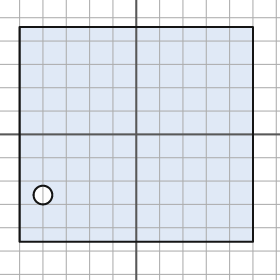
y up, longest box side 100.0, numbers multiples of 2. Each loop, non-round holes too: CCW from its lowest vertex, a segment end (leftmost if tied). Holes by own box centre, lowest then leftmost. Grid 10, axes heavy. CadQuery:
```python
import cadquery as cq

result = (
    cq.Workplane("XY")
    .moveTo(-50.0, -46.0)
    .lineTo(50.0, -46.0)
    .lineTo(50.0, 46.0)
    .lineTo(-50.0, 46.0)
    .close()
    .moveTo(-40.0, -26.0)
    .circle(4.0)
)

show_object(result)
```